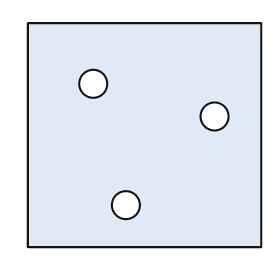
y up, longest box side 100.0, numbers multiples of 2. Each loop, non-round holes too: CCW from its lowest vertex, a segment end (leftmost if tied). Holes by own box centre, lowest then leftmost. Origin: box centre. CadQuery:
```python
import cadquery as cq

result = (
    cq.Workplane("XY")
    .moveTo(-50.0, -48.0)
    .lineTo(50.0, -48.0)
    .lineTo(50.0, 48.0)
    .lineTo(-50.0, 48.0)
    .close()
    .moveTo(-8.0, -30.0)
    .circle(6.0)
    .moveTo(30.0, 8.0)
    .circle(6.0)
    .moveTo(-22.0, 22.0)
    .circle(6.0)
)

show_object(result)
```